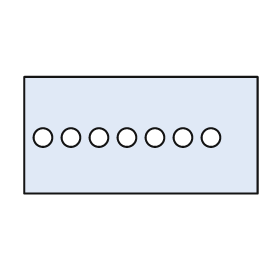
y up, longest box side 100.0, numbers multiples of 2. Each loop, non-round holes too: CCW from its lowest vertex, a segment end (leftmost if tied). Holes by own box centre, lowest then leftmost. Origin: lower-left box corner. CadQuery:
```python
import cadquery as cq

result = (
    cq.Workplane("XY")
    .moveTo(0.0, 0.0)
    .lineTo(100.0, 0.0)
    .lineTo(100.0, 50.0)
    .lineTo(0.0, 50.0)
    .close()
    .moveTo(8.0, 24.0)
    .circle(4.0)
    .moveTo(20.0, 24.0)
    .circle(4.0)
    .moveTo(32.0, 24.0)
    .circle(4.0)
    .moveTo(44.0, 24.0)
    .circle(4.0)
    .moveTo(56.0, 24.0)
    .circle(4.0)
    .moveTo(68.0, 24.0)
    .circle(4.0)
    .moveTo(80.0, 24.0)
    .circle(4.0)
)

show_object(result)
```